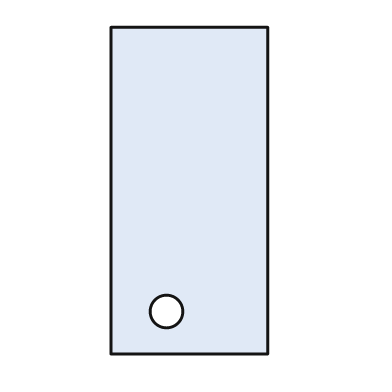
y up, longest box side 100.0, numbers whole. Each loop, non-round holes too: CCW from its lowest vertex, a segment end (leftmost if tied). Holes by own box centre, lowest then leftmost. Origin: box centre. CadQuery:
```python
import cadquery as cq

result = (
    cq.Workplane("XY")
    .moveTo(-24.0, -50.0)
    .lineTo(24.0, -50.0)
    .lineTo(24.0, 50.0)
    .lineTo(-24.0, 50.0)
    .close()
    .moveTo(-7.0, -37.0)
    .circle(5.0)
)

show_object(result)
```